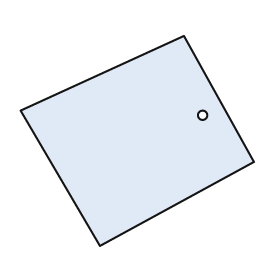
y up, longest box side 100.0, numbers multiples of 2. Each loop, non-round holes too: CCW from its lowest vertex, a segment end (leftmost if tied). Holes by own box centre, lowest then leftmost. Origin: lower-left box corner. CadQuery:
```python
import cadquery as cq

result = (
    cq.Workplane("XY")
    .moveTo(34.0, 0.0)
    .lineTo(100.0, 36.0)
    .lineTo(70.0, 90.0)
    .lineTo(0.0, 58.0)
    .close()
    .moveTo(78.0, 56.0)
    .circle(2.0)
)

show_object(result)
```